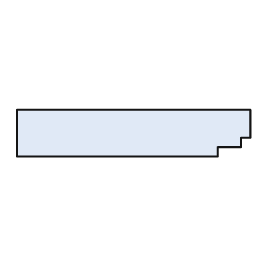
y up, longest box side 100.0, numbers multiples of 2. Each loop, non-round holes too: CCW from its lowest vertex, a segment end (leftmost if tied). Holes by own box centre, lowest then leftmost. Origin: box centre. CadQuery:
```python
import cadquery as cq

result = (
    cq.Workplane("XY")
    .moveTo(-50.0, -10.0)
    .lineTo(36.0, -10.0)
    .lineTo(36.0, -6.0)
    .lineTo(46.0, -6.0)
    .lineTo(46.0, -2.0)
    .lineTo(50.0, -2.0)
    .lineTo(50.0, 10.0)
    .lineTo(-50.0, 10.0)
    .close()
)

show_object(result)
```